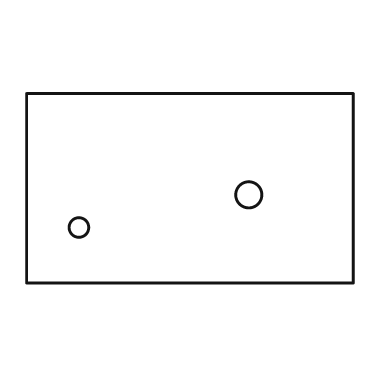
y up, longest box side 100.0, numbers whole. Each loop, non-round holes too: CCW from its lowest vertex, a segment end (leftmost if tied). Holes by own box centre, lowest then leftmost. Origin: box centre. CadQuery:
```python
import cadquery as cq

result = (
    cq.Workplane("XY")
    .moveTo(-50.0, -29.0)
    .lineTo(50.0, -29.0)
    .lineTo(50.0, 29.0)
    .lineTo(-50.0, 29.0)
    .close()
    .moveTo(-34.0, -12.0)
    .circle(3.0)
    .moveTo(18.0, -2.0)
    .circle(4.0)
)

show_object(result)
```